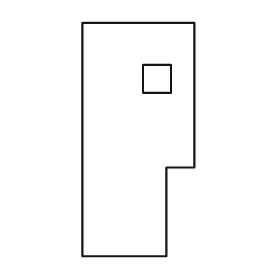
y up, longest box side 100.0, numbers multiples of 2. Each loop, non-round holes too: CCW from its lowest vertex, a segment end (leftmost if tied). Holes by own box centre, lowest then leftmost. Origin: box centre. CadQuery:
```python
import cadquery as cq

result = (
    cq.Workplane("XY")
    .moveTo(-24.0, -50.0)
    .lineTo(12.0, -50.0)
    .lineTo(12.0, -12.0)
    .lineTo(24.0, -12.0)
    .lineTo(24.0, 50.0)
    .lineTo(-24.0, 50.0)
    .close()
    .moveTo(2.0, 20.0)
    .lineTo(14.0, 20.0)
    .lineTo(14.0, 32.0)
    .lineTo(2.0, 32.0)
    .close()
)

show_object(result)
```